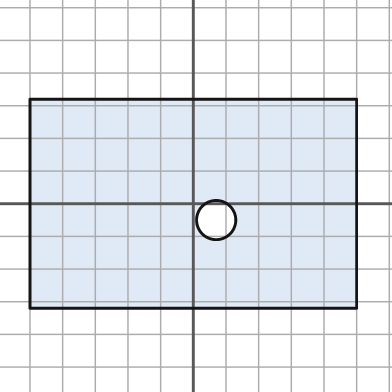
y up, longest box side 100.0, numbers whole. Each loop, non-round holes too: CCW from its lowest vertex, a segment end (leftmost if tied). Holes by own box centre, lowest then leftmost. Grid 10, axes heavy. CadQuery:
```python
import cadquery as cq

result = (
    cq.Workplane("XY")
    .moveTo(-50.0, -32.0)
    .lineTo(50.0, -32.0)
    .lineTo(50.0, 32.0)
    .lineTo(-50.0, 32.0)
    .close()
    .moveTo(7.0, -5.0)
    .circle(6.0)
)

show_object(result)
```